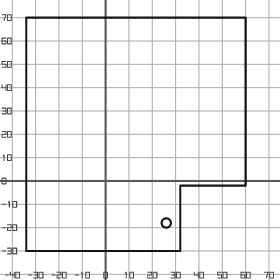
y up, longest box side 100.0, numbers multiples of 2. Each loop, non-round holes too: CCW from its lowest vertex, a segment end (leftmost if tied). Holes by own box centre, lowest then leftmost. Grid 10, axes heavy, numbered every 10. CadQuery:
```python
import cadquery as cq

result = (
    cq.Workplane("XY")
    .moveTo(-34.0, -30.0)
    .lineTo(32.0, -30.0)
    .lineTo(32.0, -2.0)
    .lineTo(60.0, -2.0)
    .lineTo(60.0, 70.0)
    .lineTo(-34.0, 70.0)
    .close()
    .moveTo(26.0, -18.0)
    .circle(2.0)
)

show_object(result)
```